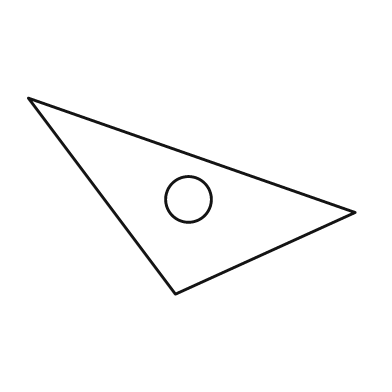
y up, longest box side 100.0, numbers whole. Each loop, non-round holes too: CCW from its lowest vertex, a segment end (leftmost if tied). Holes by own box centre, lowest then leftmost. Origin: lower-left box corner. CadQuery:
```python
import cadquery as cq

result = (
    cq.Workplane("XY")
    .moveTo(45.0, 0.0)
    .lineTo(100.0, 25.0)
    .lineTo(0.0, 60.0)
    .close()
    .moveTo(49.0, 29.0)
    .circle(7.0)
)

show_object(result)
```